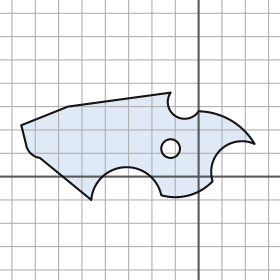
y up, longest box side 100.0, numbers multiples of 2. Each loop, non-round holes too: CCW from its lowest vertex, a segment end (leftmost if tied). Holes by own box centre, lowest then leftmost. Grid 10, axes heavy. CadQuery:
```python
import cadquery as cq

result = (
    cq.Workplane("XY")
    .moveTo(-46.0, -10.0)
    .threePointArc((-32.0, 4.0), (-16.0, -8.0))
    .threePointArc((-4.0, -8.0), (6.0, -2.0))
    .threePointArc((10.0, 12.0), (24.0, 14.0))
    .threePointArc((14.0, 24.0), (0.0, 28.0))
    .threePointArc((-10.0, 26.0), (-12.0, 36.0))
    .lineTo(-56.0, 30.0)
    .lineTo(-76.0, 22.0)
    .lineTo(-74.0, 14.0)
    .threePointArc((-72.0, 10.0), (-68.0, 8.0))
    .close()
    .moveTo(-12.0, 12.0)
    .circle(4.0)
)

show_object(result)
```